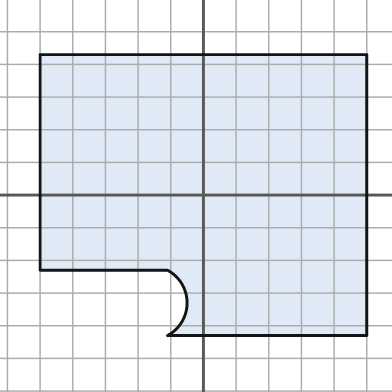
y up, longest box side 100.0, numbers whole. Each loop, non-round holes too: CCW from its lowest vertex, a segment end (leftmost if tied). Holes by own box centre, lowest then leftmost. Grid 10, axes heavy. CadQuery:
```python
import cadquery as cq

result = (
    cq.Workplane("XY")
    .moveTo(-11.0, -43.0)
    .lineTo(50.0, -43.0)
    .lineTo(50.0, 43.0)
    .lineTo(-50.0, 43.0)
    .lineTo(-50.0, -23.0)
    .lineTo(-11.0, -23.0)
    .threePointArc((-5.0, -33.0), (-11.0, -43.0))
    .close()
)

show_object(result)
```